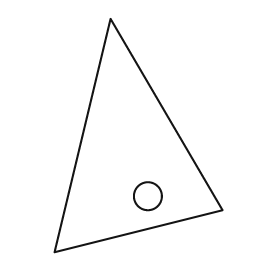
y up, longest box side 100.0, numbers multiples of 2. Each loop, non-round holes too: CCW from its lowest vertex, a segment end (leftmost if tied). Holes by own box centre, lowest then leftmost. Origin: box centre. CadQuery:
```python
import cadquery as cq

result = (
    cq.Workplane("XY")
    .moveTo(-36.0, -50.0)
    .lineTo(36.0, -32.0)
    .lineTo(-12.0, 50.0)
    .close()
    .moveTo(4.0, -26.0)
    .circle(6.0)
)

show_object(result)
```